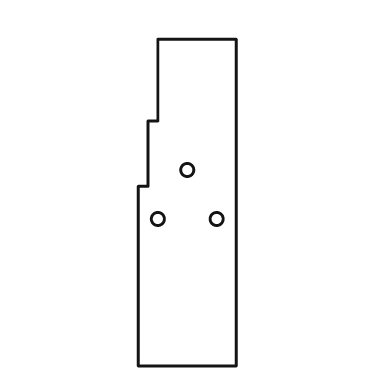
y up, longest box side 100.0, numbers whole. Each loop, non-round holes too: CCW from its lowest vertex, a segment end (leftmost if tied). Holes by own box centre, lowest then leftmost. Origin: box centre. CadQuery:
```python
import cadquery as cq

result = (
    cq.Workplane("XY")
    .moveTo(-15.0, -50.0)
    .lineTo(15.0, -50.0)
    .lineTo(15.0, 50.0)
    .lineTo(-9.0, 50.0)
    .lineTo(-9.0, 25.0)
    .lineTo(-12.0, 25.0)
    .lineTo(-12.0, 5.0)
    .lineTo(-15.0, 5.0)
    .close()
    .moveTo(-9.0, -5.0)
    .circle(2.0)
    .moveTo(9.0, -5.0)
    .circle(2.0)
    .moveTo(0.0, 10.0)
    .circle(2.0)
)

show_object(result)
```